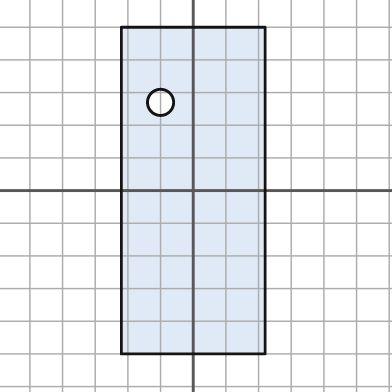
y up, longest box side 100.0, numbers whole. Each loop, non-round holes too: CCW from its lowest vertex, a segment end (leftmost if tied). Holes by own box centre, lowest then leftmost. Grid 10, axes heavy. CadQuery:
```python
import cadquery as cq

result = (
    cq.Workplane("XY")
    .moveTo(-22.0, -50.0)
    .lineTo(22.0, -50.0)
    .lineTo(22.0, 50.0)
    .lineTo(-22.0, 50.0)
    .close()
    .moveTo(-10.0, 27.0)
    .circle(4.0)
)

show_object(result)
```